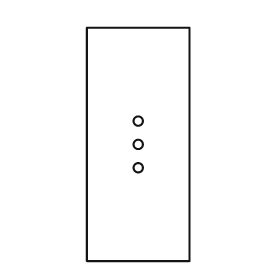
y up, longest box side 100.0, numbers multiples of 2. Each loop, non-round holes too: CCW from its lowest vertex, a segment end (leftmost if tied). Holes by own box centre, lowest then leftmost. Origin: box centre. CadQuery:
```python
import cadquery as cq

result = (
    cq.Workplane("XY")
    .moveTo(-22.0, -50.0)
    .lineTo(22.0, -50.0)
    .lineTo(22.0, 50.0)
    .lineTo(-22.0, 50.0)
    .close()
    .moveTo(0.0, -10.0)
    .circle(2.0)
    .moveTo(0.0, 0.0)
    .circle(2.0)
    .moveTo(0.0, 10.0)
    .circle(2.0)
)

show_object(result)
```